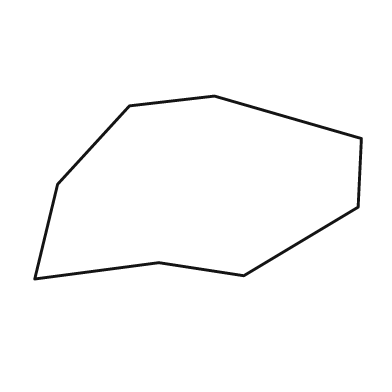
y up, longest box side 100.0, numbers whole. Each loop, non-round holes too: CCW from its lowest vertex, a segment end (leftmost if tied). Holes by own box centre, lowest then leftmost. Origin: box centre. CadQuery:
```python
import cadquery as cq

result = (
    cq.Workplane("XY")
    .moveTo(-50.0, -28.0)
    .lineTo(-12.0, -23.0)
    .lineTo(14.0, -27.0)
    .lineTo(49.0, -6.0)
    .lineTo(50.0, 15.0)
    .lineTo(5.0, 28.0)
    .lineTo(-21.0, 25.0)
    .lineTo(-43.0, 1.0)
    .close()
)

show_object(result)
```